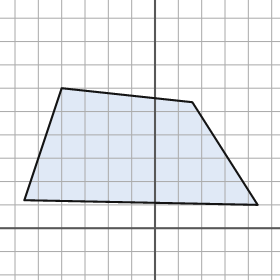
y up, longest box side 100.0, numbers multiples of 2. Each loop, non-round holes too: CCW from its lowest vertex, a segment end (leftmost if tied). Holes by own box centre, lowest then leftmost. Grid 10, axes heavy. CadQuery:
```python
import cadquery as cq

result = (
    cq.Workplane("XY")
    .moveTo(44.0, 10.0)
    .lineTo(16.0, 54.0)
    .lineTo(-40.0, 60.0)
    .lineTo(-56.0, 12.0)
    .close()
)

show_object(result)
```